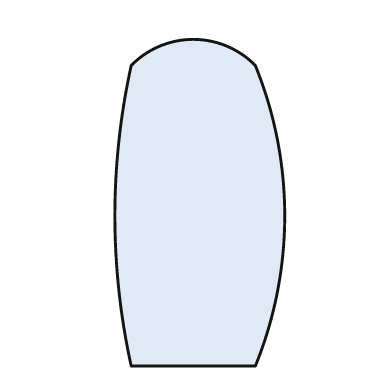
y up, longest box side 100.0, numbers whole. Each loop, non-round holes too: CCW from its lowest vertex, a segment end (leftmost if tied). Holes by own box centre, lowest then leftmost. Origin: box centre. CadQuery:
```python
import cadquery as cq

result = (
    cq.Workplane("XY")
    .moveTo(-21.0, -50.0)
    .lineTo(17.0, -50.0)
    .threePointArc((26.0, -4.0), (17.0, 42.0))
    .threePointArc((-2.0, 50.0), (-21.0, 42.0))
    .threePointArc((-26.0, -4.0), (-21.0, -50.0))
    .close()
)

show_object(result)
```